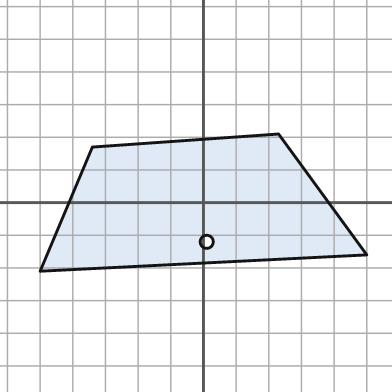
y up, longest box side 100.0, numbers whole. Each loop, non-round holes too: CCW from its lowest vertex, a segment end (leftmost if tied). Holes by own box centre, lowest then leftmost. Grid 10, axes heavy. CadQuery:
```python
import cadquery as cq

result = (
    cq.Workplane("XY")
    .moveTo(-50.0, -21.0)
    .lineTo(50.0, -16.0)
    .lineTo(23.0, 21.0)
    .lineTo(-34.0, 17.0)
    .close()
    .moveTo(1.0, -12.0)
    .circle(2.0)
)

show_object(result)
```